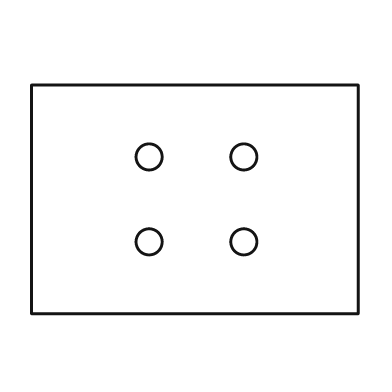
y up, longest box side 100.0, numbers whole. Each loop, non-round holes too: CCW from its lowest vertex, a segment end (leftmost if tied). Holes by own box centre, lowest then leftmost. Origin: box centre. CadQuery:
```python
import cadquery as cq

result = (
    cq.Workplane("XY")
    .moveTo(-50.0, -35.0)
    .lineTo(50.0, -35.0)
    .lineTo(50.0, 35.0)
    .lineTo(-50.0, 35.0)
    .close()
    .moveTo(-14.0, -13.0)
    .circle(4.0)
    .moveTo(15.0, -13.0)
    .circle(4.0)
    .moveTo(-14.0, 13.0)
    .circle(4.0)
    .moveTo(15.0, 13.0)
    .circle(4.0)
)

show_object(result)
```